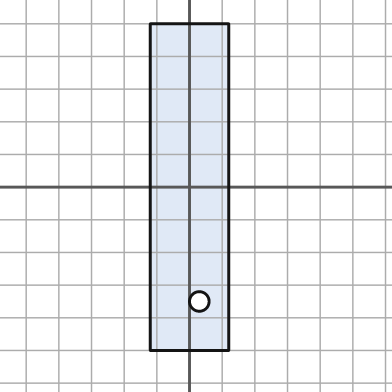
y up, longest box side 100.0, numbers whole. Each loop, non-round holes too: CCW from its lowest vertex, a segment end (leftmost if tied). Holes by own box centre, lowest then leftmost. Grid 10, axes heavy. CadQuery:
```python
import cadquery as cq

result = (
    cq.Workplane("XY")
    .moveTo(-12.0, -50.0)
    .lineTo(12.0, -50.0)
    .lineTo(12.0, 50.0)
    .lineTo(-12.0, 50.0)
    .close()
    .moveTo(3.0, -35.0)
    .circle(3.0)
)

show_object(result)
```